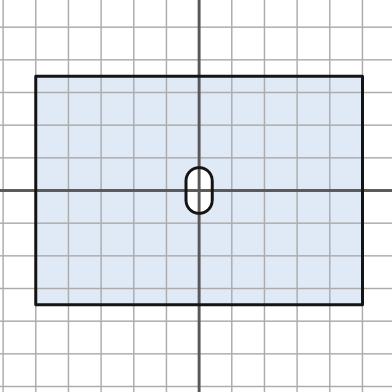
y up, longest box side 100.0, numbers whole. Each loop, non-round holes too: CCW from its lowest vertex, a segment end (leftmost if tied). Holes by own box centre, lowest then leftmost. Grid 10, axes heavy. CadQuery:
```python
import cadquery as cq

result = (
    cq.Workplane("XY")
    .moveTo(-50.0, -35.0)
    .lineTo(50.0, -35.0)
    .lineTo(50.0, 35.0)
    .lineTo(-50.0, 35.0)
    .close()
    .moveTo(-4.0, -3.0)
    .threePointArc((0.0, -7.0), (4.0, -3.0))
    .lineTo(4.0, 3.0)
    .threePointArc((0.0, 7.0), (-4.0, 3.0))
    .close()
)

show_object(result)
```